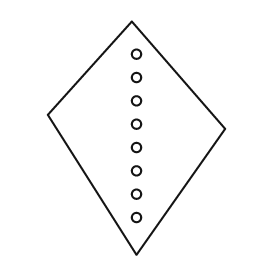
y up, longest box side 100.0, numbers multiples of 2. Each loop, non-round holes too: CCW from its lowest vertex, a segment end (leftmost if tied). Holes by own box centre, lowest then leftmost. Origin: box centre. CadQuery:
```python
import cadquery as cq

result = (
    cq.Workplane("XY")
    .moveTo(0.0, -50.0)
    .lineTo(38.0, 4.0)
    .lineTo(-2.0, 50.0)
    .lineTo(-38.0, 10.0)
    .close()
    .moveTo(0.0, -34.0)
    .circle(2.0)
    .moveTo(0.0, -24.0)
    .circle(2.0)
    .moveTo(0.0, -14.0)
    .circle(2.0)
    .moveTo(0.0, -4.0)
    .circle(2.0)
    .moveTo(0.0, 6.0)
    .circle(2.0)
    .moveTo(0.0, 16.0)
    .circle(2.0)
    .moveTo(0.0, 26.0)
    .circle(2.0)
    .moveTo(0.0, 36.0)
    .circle(2.0)
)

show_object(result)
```